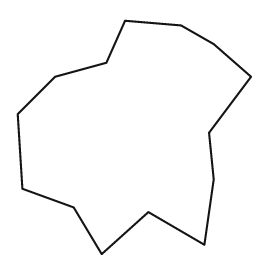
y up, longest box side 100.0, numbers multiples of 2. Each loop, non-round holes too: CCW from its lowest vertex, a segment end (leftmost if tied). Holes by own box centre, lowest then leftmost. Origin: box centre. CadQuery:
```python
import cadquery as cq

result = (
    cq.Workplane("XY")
    .moveTo(-14.0, -50.0)
    .lineTo(6.0, -32.0)
    .lineTo(30.0, -46.0)
    .lineTo(34.0, -18.0)
    .lineTo(32.0, 2.0)
    .lineTo(50.0, 26.0)
    .lineTo(34.0, 40.0)
    .lineTo(20.0, 48.0)
    .lineTo(-4.0, 50.0)
    .lineTo(-12.0, 32.0)
    .lineTo(-34.0, 26.0)
    .lineTo(-50.0, 10.0)
    .lineTo(-48.0, -22.0)
    .lineTo(-26.0, -30.0)
    .close()
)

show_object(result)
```